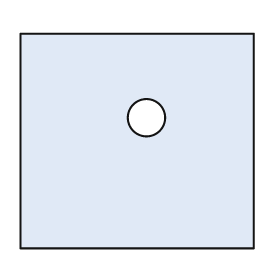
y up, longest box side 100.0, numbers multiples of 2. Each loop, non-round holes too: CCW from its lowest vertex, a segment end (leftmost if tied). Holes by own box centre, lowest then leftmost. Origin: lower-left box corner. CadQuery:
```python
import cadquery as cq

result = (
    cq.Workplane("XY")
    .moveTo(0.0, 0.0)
    .lineTo(100.0, 0.0)
    .lineTo(100.0, 92.0)
    .lineTo(0.0, 92.0)
    .close()
    .moveTo(54.0, 56.0)
    .circle(8.0)
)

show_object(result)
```